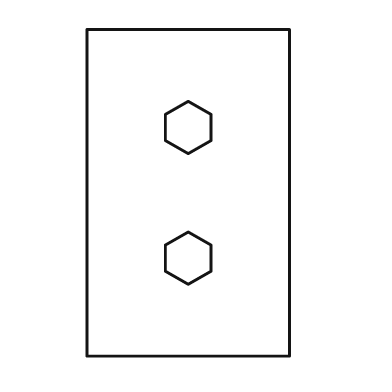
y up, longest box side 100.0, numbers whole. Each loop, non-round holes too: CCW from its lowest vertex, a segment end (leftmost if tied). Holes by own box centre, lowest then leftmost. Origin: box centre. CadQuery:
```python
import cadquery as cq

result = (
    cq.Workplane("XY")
    .moveTo(-31.0, -50.0)
    .lineTo(31.0, -50.0)
    .lineTo(31.0, 50.0)
    .lineTo(-31.0, 50.0)
    .close()
    .moveTo(0.0, -28.0)
    .lineTo(7.0, -24.0)
    .lineTo(7.0, -16.0)
    .lineTo(0.0, -12.0)
    .lineTo(-7.0, -16.0)
    .lineTo(-7.0, -24.0)
    .close()
    .moveTo(0.0, 12.0)
    .lineTo(7.0, 16.0)
    .lineTo(7.0, 24.0)
    .lineTo(0.0, 28.0)
    .lineTo(-7.0, 24.0)
    .lineTo(-7.0, 16.0)
    .close()
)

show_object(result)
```